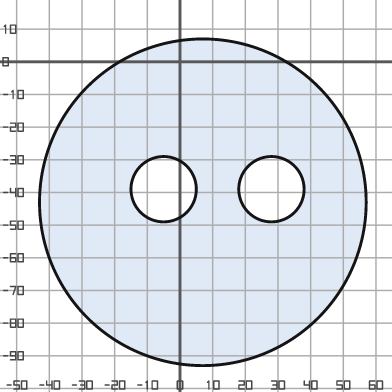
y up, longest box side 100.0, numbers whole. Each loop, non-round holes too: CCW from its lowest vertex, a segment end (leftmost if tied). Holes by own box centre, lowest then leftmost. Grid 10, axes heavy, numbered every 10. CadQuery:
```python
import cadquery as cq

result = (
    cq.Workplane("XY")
    .moveTo(7.0, -43.0)
    .circle(50.0)
    .moveTo(-5.0, -39.0)
    .circle(10.0)
    .moveTo(28.0, -39.0)
    .circle(10.0)
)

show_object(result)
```